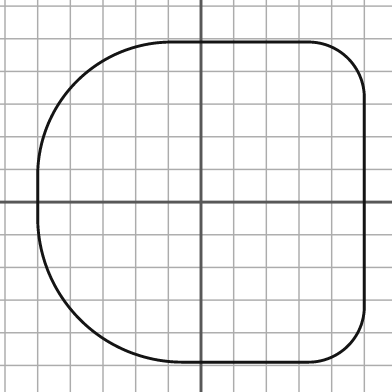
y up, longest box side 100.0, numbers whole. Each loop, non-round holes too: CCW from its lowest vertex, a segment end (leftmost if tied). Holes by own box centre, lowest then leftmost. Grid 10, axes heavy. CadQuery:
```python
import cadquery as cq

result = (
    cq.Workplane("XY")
    .moveTo(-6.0, -49.0)
    .lineTo(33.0, -49.0)
    .threePointArc((45.0, -44.0), (50.0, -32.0))
    .lineTo(50.0, 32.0)
    .threePointArc((45.0, 44.0), (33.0, 49.0))
    .lineTo(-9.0, 49.0)
    .threePointArc((-38.0, 37.0), (-50.0, 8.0))
    .lineTo(-50.0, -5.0)
    .threePointArc((-37.0, -36.0), (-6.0, -49.0))
    .close()
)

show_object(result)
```